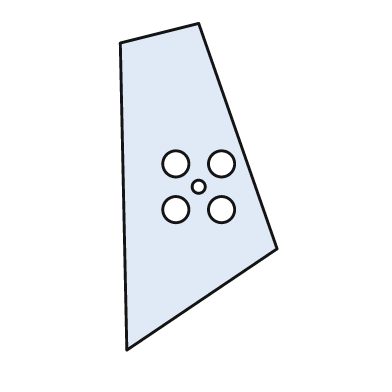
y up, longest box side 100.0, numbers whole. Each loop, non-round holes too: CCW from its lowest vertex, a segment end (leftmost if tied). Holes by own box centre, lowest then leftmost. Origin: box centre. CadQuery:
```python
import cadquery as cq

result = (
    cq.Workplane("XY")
    .moveTo(-22.0, -50.0)
    .lineTo(24.0, -19.0)
    .lineTo(0.0, 50.0)
    .lineTo(-24.0, 44.0)
    .close()
    .moveTo(-7.0, -7.0)
    .circle(4.0)
    .moveTo(7.0, -7.0)
    .circle(4.0)
    .moveTo(0.0, 0.0)
    .circle(2.0)
    .moveTo(-7.0, 7.0)
    .circle(4.0)
    .moveTo(7.0, 7.0)
    .circle(4.0)
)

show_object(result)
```